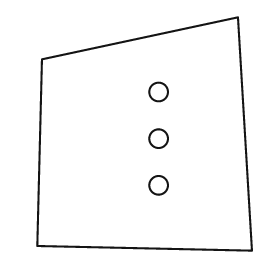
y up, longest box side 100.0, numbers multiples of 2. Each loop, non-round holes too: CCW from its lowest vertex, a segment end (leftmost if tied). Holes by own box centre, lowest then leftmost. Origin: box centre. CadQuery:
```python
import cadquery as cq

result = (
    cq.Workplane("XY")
    .moveTo(46.0, -50.0)
    .lineTo(40.0, 50.0)
    .lineTo(-44.0, 32.0)
    .lineTo(-46.0, -48.0)
    .close()
    .moveTo(6.0, -22.0)
    .circle(4.0)
    .moveTo(6.0, -2.0)
    .circle(4.0)
    .moveTo(6.0, 18.0)
    .circle(4.0)
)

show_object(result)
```